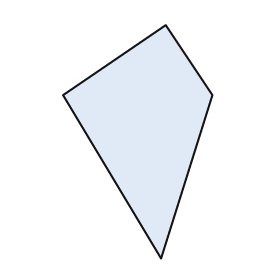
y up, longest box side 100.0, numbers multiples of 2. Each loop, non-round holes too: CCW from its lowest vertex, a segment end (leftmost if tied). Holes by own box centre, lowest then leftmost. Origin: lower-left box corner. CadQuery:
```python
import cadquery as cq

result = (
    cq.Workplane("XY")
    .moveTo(42.0, 0.0)
    .lineTo(64.0, 70.0)
    .lineTo(44.0, 100.0)
    .lineTo(0.0, 70.0)
    .close()
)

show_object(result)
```